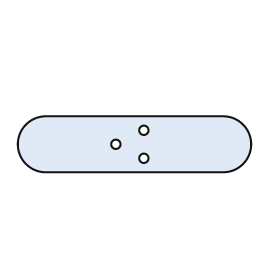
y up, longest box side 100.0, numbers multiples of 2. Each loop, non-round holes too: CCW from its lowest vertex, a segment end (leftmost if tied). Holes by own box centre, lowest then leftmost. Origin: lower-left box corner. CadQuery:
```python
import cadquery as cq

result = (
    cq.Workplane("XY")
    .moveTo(12.0, 0.0)
    .lineTo(88.0, 0.0)
    .threePointArc((100.0, 12.0), (88.0, 24.0))
    .lineTo(12.0, 24.0)
    .threePointArc((0.0, 12.0), (12.0, 0.0))
    .close()
    .moveTo(54.0, 6.0)
    .circle(2.0)
    .moveTo(42.0, 12.0)
    .circle(2.0)
    .moveTo(54.0, 18.0)
    .circle(2.0)
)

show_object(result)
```